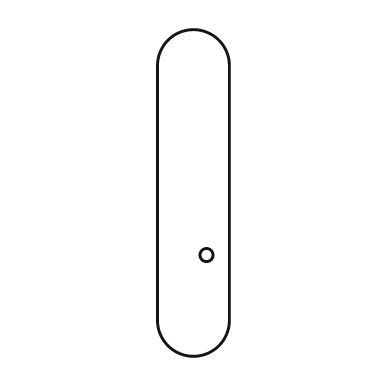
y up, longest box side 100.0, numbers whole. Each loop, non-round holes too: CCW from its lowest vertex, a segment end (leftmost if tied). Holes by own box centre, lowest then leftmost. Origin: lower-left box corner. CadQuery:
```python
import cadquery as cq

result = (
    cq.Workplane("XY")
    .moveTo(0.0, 11.0)
    .threePointArc((11.0, 0.0), (22.0, 11.0))
    .lineTo(22.0, 89.0)
    .threePointArc((11.0, 100.0), (0.0, 89.0))
    .close()
    .moveTo(15.0, 31.0)
    .circle(2.0)
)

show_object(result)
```